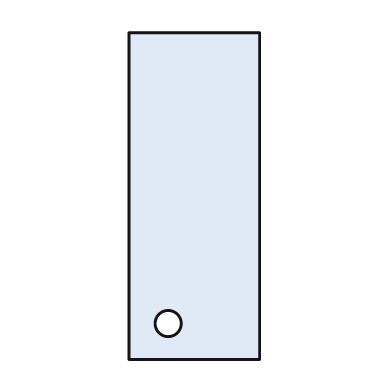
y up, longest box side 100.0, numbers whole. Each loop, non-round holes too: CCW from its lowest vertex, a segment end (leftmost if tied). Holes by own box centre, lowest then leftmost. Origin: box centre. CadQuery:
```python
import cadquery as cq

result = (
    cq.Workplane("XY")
    .moveTo(-20.0, -50.0)
    .lineTo(20.0, -50.0)
    .lineTo(20.0, 50.0)
    .lineTo(-20.0, 50.0)
    .close()
    .moveTo(-8.0, -39.0)
    .circle(4.0)
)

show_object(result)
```